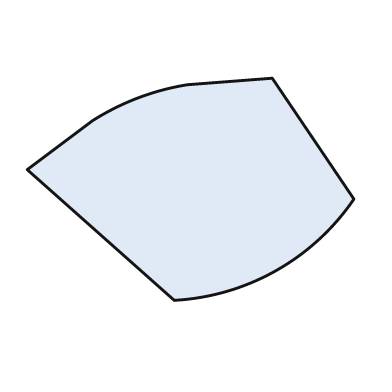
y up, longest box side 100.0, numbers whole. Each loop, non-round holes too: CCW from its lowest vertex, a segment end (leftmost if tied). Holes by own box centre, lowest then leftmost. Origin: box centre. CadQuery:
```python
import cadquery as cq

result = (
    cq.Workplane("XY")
    .moveTo(-5.0, -34.0)
    .threePointArc((26.0, -25.0), (50.0, -3.0))
    .lineTo(25.0, 34.0)
    .lineTo(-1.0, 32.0)
    .threePointArc((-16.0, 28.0), (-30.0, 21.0))
    .lineTo(-50.0, 6.0)
    .close()
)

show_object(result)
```